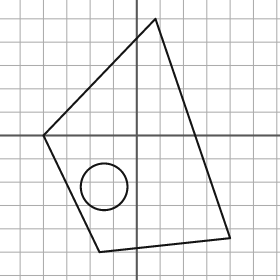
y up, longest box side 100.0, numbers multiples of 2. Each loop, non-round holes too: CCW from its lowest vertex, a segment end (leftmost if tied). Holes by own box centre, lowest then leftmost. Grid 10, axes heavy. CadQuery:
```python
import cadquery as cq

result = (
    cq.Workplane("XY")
    .moveTo(-16.0, -50.0)
    .lineTo(40.0, -44.0)
    .lineTo(8.0, 50.0)
    .lineTo(-40.0, 0.0)
    .close()
    .moveTo(-14.0, -22.0)
    .circle(10.0)
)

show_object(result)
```